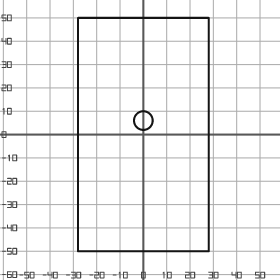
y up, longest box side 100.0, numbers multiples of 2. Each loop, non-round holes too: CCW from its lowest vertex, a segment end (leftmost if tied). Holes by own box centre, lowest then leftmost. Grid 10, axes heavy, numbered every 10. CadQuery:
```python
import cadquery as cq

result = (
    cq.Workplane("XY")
    .moveTo(-28.0, -50.0)
    .lineTo(28.0, -50.0)
    .lineTo(28.0, 50.0)
    .lineTo(-28.0, 50.0)
    .close()
    .moveTo(0.0, 6.0)
    .circle(4.0)
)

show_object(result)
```